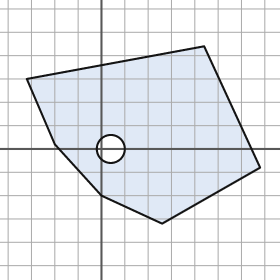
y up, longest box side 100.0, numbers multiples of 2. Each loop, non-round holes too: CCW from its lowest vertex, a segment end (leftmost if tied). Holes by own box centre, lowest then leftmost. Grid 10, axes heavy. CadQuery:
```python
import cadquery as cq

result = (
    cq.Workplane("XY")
    .moveTo(26.0, -32.0)
    .lineTo(68.0, -8.0)
    .lineTo(44.0, 44.0)
    .lineTo(-32.0, 30.0)
    .lineTo(-20.0, 2.0)
    .lineTo(0.0, -20.0)
    .close()
    .moveTo(4.0, 0.0)
    .circle(6.0)
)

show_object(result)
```